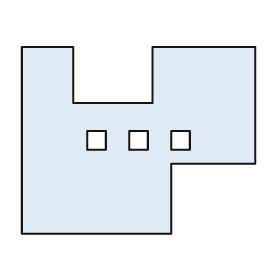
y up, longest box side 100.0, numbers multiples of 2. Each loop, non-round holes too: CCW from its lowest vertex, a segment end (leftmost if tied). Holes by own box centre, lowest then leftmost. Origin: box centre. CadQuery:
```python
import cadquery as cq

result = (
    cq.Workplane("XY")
    .moveTo(-50.0, -40.0)
    .lineTo(14.0, -40.0)
    .lineTo(14.0, -10.0)
    .lineTo(50.0, -10.0)
    .lineTo(50.0, 40.0)
    .lineTo(6.0, 40.0)
    .lineTo(6.0, 16.0)
    .lineTo(-28.0, 16.0)
    .lineTo(-28.0, 40.0)
    .lineTo(-50.0, 40.0)
    .close()
    .moveTo(-22.0, -4.0)
    .lineTo(-14.0, -4.0)
    .lineTo(-14.0, 4.0)
    .lineTo(-22.0, 4.0)
    .close()
    .moveTo(-4.0, -4.0)
    .lineTo(4.0, -4.0)
    .lineTo(4.0, 4.0)
    .lineTo(-4.0, 4.0)
    .close()
    .moveTo(14.0, -4.0)
    .lineTo(22.0, -4.0)
    .lineTo(22.0, 4.0)
    .lineTo(14.0, 4.0)
    .close()
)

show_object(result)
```